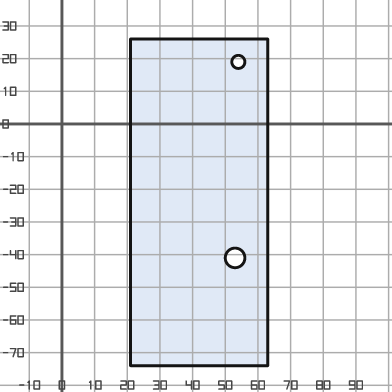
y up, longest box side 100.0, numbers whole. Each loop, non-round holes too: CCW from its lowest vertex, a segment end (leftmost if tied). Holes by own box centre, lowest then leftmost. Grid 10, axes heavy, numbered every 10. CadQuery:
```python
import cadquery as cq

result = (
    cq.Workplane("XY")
    .moveTo(21.0, -74.0)
    .lineTo(63.0, -74.0)
    .lineTo(63.0, 26.0)
    .lineTo(21.0, 26.0)
    .close()
    .moveTo(53.0, -41.0)
    .circle(3.0)
    .moveTo(54.0, 19.0)
    .circle(2.0)
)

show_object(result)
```